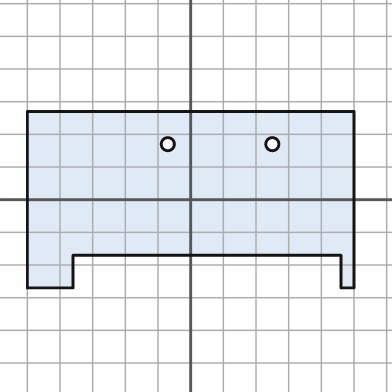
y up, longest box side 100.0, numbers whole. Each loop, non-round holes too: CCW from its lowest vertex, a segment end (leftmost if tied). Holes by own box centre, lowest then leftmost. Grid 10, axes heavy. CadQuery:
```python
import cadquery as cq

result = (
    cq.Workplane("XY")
    .moveTo(-50.0, -27.0)
    .lineTo(-36.0, -27.0)
    .lineTo(-36.0, -17.0)
    .lineTo(46.0, -17.0)
    .lineTo(46.0, -27.0)
    .lineTo(50.0, -27.0)
    .lineTo(50.0, 27.0)
    .lineTo(-50.0, 27.0)
    .close()
    .moveTo(-7.0, 17.0)
    .circle(2.0)
    .moveTo(25.0, 17.0)
    .circle(2.0)
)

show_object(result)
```